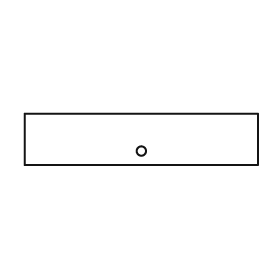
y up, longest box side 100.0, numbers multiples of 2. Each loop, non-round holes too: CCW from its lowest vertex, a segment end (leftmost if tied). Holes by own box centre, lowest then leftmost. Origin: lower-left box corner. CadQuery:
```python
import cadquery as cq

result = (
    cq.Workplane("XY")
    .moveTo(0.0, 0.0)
    .lineTo(100.0, 0.0)
    .lineTo(100.0, 22.0)
    .lineTo(0.0, 22.0)
    .close()
    .moveTo(50.0, 6.0)
    .circle(2.0)
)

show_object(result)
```